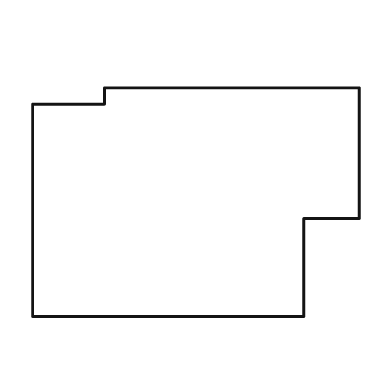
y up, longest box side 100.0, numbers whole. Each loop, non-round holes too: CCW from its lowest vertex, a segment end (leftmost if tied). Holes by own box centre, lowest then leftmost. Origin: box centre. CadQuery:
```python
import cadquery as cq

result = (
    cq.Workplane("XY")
    .moveTo(-50.0, -35.0)
    .lineTo(33.0, -35.0)
    .lineTo(33.0, -5.0)
    .lineTo(50.0, -5.0)
    .lineTo(50.0, 35.0)
    .lineTo(-28.0, 35.0)
    .lineTo(-28.0, 30.0)
    .lineTo(-50.0, 30.0)
    .close()
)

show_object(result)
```